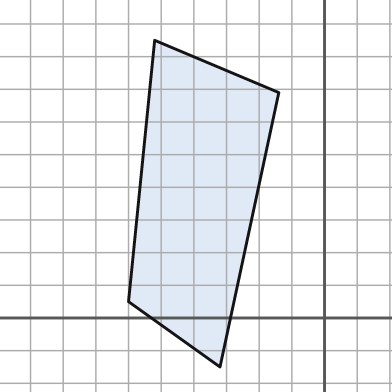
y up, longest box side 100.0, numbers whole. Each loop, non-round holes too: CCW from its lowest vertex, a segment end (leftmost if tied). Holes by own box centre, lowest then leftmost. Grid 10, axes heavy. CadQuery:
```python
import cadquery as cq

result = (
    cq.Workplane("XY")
    .moveTo(-32.0, -15.0)
    .lineTo(-14.0, 69.0)
    .lineTo(-52.0, 85.0)
    .lineTo(-60.0, 5.0)
    .close()
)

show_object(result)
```